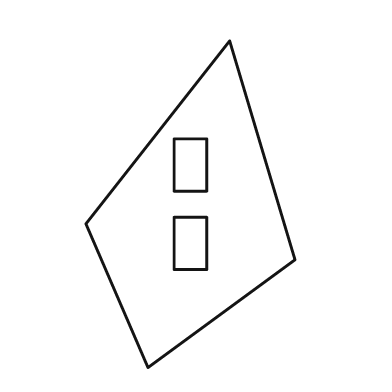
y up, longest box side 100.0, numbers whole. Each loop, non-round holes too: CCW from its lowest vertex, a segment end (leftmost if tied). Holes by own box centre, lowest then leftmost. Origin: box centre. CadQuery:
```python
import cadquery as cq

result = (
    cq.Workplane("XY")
    .moveTo(-13.0, -50.0)
    .lineTo(32.0, -17.0)
    .lineTo(12.0, 50.0)
    .lineTo(-32.0, -6.0)
    .close()
    .moveTo(-5.0, -20.0)
    .lineTo(5.0, -20.0)
    .lineTo(5.0, -4.0)
    .lineTo(-5.0, -4.0)
    .close()
    .moveTo(-5.0, 4.0)
    .lineTo(5.0, 4.0)
    .lineTo(5.0, 20.0)
    .lineTo(-5.0, 20.0)
    .close()
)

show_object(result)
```